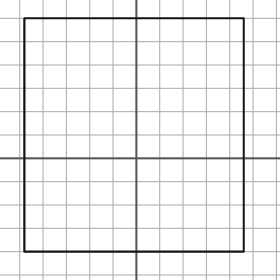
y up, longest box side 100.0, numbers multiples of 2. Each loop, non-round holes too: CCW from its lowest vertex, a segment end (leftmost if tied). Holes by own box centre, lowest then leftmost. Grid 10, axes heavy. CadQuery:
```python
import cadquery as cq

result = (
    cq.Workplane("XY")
    .moveTo(-48.0, -40.0)
    .lineTo(46.0, -40.0)
    .lineTo(46.0, 60.0)
    .lineTo(-48.0, 60.0)
    .close()
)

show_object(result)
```